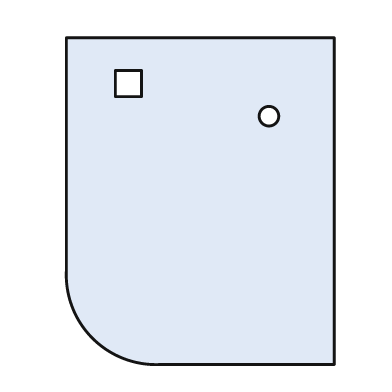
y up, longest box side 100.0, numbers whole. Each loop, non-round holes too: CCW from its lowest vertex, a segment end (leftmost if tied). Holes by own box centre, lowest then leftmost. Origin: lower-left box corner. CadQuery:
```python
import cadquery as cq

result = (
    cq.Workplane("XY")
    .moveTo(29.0, 0.0)
    .lineTo(82.0, 0.0)
    .lineTo(82.0, 100.0)
    .lineTo(0.0, 100.0)
    .lineTo(0.0, 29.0)
    .threePointArc((8.0, 8.0), (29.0, 0.0))
    .close()
    .moveTo(62.0, 76.0)
    .circle(3.0)
    .moveTo(15.0, 82.0)
    .lineTo(23.0, 82.0)
    .lineTo(23.0, 90.0)
    .lineTo(15.0, 90.0)
    .close()
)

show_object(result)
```